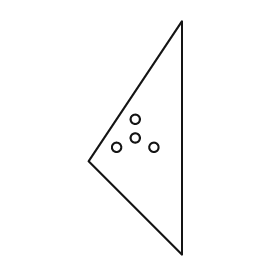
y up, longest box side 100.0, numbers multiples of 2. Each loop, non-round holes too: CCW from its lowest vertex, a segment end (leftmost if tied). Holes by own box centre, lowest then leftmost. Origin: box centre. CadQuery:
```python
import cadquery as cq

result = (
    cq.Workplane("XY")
    .moveTo(20.0, -50.0)
    .lineTo(20.0, 50.0)
    .lineTo(-20.0, -10.0)
    .close()
    .moveTo(-8.0, -4.0)
    .circle(2.0)
    .moveTo(8.0, -4.0)
    .circle(2.0)
    .moveTo(0.0, 0.0)
    .circle(2.0)
    .moveTo(0.0, 8.0)
    .circle(2.0)
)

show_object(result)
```